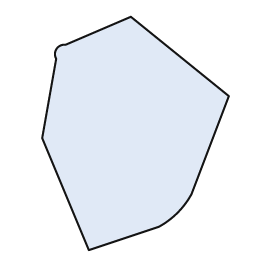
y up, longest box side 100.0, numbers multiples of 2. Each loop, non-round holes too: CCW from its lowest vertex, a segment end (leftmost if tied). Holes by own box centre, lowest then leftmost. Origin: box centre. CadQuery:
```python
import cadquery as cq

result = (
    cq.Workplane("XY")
    .moveTo(-20.0, -50.0)
    .lineTo(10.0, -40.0)
    .threePointArc((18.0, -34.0), (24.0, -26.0))
    .lineTo(40.0, 16.0)
    .lineTo(-2.0, 50.0)
    .lineTo(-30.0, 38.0)
    .threePointArc((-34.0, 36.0), (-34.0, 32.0))
    .lineTo(-40.0, -2.0)
    .close()
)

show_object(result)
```